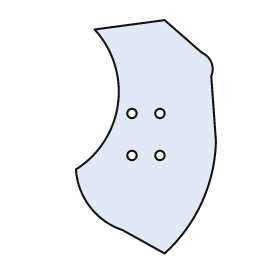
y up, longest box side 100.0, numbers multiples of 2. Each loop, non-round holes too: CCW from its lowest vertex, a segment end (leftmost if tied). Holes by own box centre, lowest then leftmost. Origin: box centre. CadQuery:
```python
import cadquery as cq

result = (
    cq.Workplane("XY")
    .moveTo(8.0, -50.0)
    .threePointArc((24.0, -28.0), (30.0, -2.0))
    .lineTo(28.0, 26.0)
    .threePointArc((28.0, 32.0), (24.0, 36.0))
    .lineTo(8.0, 50.0)
    .lineTo(-22.0, 46.0)
    .threePointArc((-12.0, 14.0), (-30.0, -14.0))
    .threePointArc((-24.0, -30.0), (-10.0, -40.0))
    .close()
    .moveTo(-6.0, -8.0)
    .circle(2.0)
    .moveTo(6.0, -8.0)
    .circle(2.0)
    .moveTo(-6.0, 10.0)
    .circle(2.0)
    .moveTo(6.0, 10.0)
    .circle(2.0)
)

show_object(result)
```